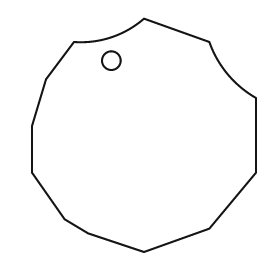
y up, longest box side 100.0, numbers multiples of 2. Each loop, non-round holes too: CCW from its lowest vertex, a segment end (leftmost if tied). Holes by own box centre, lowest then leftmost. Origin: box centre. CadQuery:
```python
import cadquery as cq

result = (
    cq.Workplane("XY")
    .moveTo(0.0, -50.0)
    .lineTo(28.0, -40.0)
    .lineTo(48.0, -16.0)
    .lineTo(48.0, 16.0)
    .threePointArc((36.0, 26.0), (28.0, 40.0))
    .lineTo(0.0, 50.0)
    .threePointArc((-14.0, 42.0), (-30.0, 40.0))
    .lineTo(-42.0, 24.0)
    .lineTo(-48.0, 4.0)
    .lineTo(-48.0, -16.0)
    .lineTo(-34.0, -36.0)
    .lineTo(-24.0, -42.0)
    .close()
    .moveTo(-14.0, 32.0)
    .circle(4.0)
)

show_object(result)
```